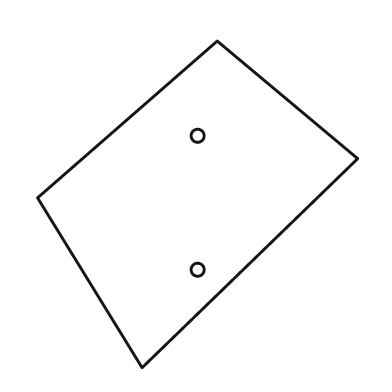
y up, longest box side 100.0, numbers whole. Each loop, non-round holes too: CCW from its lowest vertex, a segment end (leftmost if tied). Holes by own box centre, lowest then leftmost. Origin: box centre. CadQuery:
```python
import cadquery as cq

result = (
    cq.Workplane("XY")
    .moveTo(-17.0, -50.0)
    .lineTo(49.0, 14.0)
    .lineTo(6.0, 50.0)
    .lineTo(-49.0, 2.0)
    .close()
    .moveTo(0.0, -20.0)
    .circle(2.0)
    .moveTo(0.0, 21.0)
    .circle(2.0)
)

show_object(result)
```